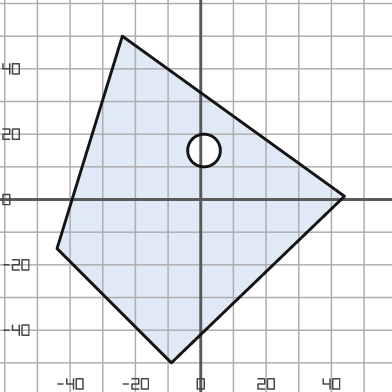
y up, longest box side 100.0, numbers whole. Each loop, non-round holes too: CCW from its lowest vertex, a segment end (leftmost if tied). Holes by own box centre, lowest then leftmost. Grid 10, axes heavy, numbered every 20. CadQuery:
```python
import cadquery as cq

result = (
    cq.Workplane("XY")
    .moveTo(-9.0, -50.0)
    .lineTo(44.0, 1.0)
    .lineTo(-24.0, 50.0)
    .lineTo(-44.0, -15.0)
    .close()
    .moveTo(1.0, 15.0)
    .circle(5.0)
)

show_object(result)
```